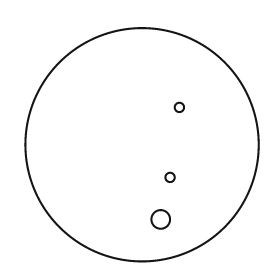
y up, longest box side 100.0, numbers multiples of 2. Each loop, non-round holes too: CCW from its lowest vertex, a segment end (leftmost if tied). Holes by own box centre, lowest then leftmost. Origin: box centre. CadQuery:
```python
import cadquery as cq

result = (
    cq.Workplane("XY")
    .moveTo(0.0, 0.0)
    .circle(50.0)
    .moveTo(8.0, -32.0)
    .circle(4.0)
    .moveTo(12.0, -14.0)
    .circle(2.0)
    .moveTo(16.0, 16.0)
    .circle(2.0)
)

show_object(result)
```